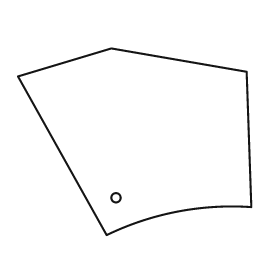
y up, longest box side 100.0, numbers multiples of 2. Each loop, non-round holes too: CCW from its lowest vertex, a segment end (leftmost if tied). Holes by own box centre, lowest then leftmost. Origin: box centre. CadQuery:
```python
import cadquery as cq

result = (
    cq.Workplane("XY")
    .moveTo(-12.0, -40.0)
    .threePointArc((18.0, -30.0), (50.0, -28.0))
    .lineTo(48.0, 30.0)
    .lineTo(-10.0, 40.0)
    .lineTo(-50.0, 28.0)
    .close()
    .moveTo(-8.0, -24.0)
    .circle(2.0)
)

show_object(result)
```